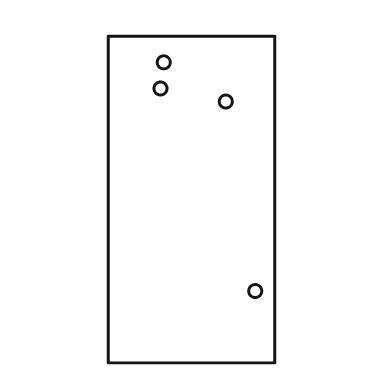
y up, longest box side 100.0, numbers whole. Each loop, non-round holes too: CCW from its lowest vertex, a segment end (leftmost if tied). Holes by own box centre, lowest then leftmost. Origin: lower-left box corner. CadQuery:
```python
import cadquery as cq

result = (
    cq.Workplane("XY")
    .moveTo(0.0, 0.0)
    .lineTo(51.0, 0.0)
    .lineTo(51.0, 100.0)
    .lineTo(0.0, 100.0)
    .close()
    .moveTo(45.0, 22.0)
    .circle(2.0)
    .moveTo(36.0, 80.0)
    .circle(2.0)
    .moveTo(16.0, 84.0)
    .circle(2.0)
    .moveTo(17.0, 92.0)
    .circle(2.0)
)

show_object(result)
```